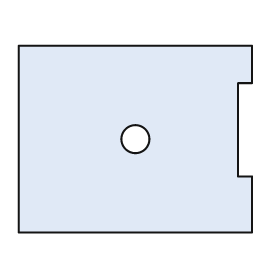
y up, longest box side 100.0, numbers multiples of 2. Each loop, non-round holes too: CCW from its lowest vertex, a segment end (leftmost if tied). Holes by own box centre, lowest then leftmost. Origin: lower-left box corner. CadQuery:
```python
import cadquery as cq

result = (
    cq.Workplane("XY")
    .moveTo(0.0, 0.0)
    .lineTo(100.0, 0.0)
    .lineTo(100.0, 24.0)
    .lineTo(94.0, 24.0)
    .lineTo(94.0, 64.0)
    .lineTo(100.0, 64.0)
    .lineTo(100.0, 80.0)
    .lineTo(0.0, 80.0)
    .close()
    .moveTo(50.0, 40.0)
    .circle(6.0)
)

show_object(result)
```